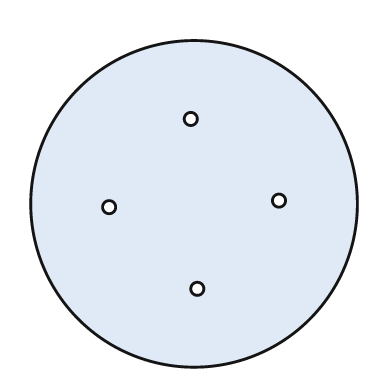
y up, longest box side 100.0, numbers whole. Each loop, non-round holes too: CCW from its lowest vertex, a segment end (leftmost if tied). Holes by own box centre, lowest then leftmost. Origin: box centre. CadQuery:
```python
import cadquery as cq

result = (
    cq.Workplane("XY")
    .moveTo(0.0, 0.0)
    .circle(50.0)
    .moveTo(1.0, -26.0)
    .circle(2.0)
    .moveTo(-26.0, -1.0)
    .circle(2.0)
    .moveTo(26.0, 1.0)
    .circle(2.0)
    .moveTo(-1.0, 26.0)
    .circle(2.0)
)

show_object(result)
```